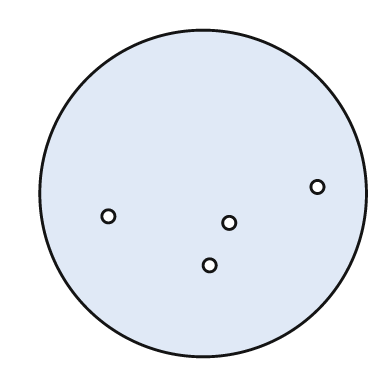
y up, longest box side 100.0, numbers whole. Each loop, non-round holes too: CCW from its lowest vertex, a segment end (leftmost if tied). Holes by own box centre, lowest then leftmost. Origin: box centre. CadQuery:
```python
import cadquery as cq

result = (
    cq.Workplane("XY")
    .moveTo(0.0, 0.0)
    .circle(50.0)
    .moveTo(2.0, -22.0)
    .circle(2.0)
    .moveTo(8.0, -9.0)
    .circle(2.0)
    .moveTo(-29.0, -7.0)
    .circle(2.0)
    .moveTo(35.0, 2.0)
    .circle(2.0)
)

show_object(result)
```